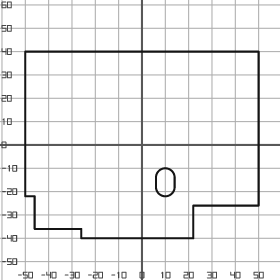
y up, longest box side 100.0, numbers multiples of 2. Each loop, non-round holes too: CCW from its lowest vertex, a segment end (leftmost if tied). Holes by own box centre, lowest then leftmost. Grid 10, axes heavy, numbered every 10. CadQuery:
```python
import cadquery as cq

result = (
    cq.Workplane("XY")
    .moveTo(-26.0, -40.0)
    .lineTo(22.0, -40.0)
    .lineTo(22.0, -26.0)
    .lineTo(50.0, -26.0)
    .lineTo(50.0, 40.0)
    .lineTo(-50.0, 40.0)
    .lineTo(-50.0, -22.0)
    .lineTo(-46.0, -22.0)
    .lineTo(-46.0, -36.0)
    .lineTo(-26.0, -36.0)
    .close()
    .moveTo(6.0, -18.0)
    .threePointArc((10.0, -22.0), (14.0, -18.0))
    .lineTo(14.0, -14.0)
    .threePointArc((10.0, -10.0), (6.0, -14.0))
    .close()
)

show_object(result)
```